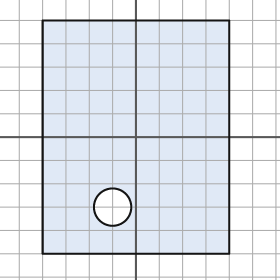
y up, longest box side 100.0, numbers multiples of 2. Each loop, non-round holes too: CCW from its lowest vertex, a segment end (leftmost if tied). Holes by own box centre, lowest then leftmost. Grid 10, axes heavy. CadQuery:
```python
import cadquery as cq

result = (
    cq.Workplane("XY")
    .moveTo(-40.0, -50.0)
    .lineTo(40.0, -50.0)
    .lineTo(40.0, 50.0)
    .lineTo(-40.0, 50.0)
    .close()
    .moveTo(-10.0, -30.0)
    .circle(8.0)
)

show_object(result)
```